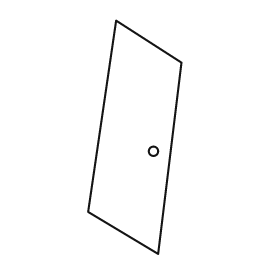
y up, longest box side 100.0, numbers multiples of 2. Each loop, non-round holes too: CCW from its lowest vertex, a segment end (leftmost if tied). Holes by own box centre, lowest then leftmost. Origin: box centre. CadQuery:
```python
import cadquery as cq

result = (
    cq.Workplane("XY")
    .moveTo(10.0, -50.0)
    .lineTo(20.0, 32.0)
    .lineTo(-8.0, 50.0)
    .lineTo(-20.0, -32.0)
    .close()
    .moveTo(8.0, -6.0)
    .circle(2.0)
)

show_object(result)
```